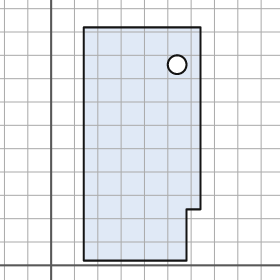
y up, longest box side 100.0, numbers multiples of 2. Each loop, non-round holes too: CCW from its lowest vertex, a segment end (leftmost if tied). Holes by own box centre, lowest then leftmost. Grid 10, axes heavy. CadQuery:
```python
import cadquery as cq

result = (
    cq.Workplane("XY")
    .moveTo(14.0, 2.0)
    .lineTo(58.0, 2.0)
    .lineTo(58.0, 24.0)
    .lineTo(64.0, 24.0)
    .lineTo(64.0, 102.0)
    .lineTo(14.0, 102.0)
    .close()
    .moveTo(54.0, 86.0)
    .circle(4.0)
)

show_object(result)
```